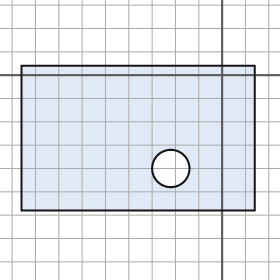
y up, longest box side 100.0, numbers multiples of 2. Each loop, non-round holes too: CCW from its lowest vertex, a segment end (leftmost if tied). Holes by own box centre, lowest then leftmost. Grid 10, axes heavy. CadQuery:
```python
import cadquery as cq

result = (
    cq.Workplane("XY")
    .moveTo(-86.0, -58.0)
    .lineTo(14.0, -58.0)
    .lineTo(14.0, 4.0)
    .lineTo(-86.0, 4.0)
    .close()
    .moveTo(-22.0, -40.0)
    .circle(8.0)
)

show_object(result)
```